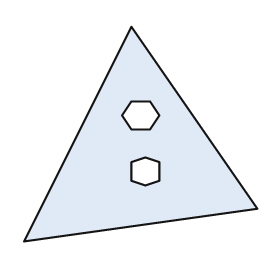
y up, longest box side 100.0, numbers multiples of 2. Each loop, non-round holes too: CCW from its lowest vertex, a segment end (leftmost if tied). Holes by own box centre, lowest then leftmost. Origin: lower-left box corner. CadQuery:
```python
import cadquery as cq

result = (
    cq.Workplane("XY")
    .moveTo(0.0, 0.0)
    .lineTo(100.0, 14.0)
    .lineTo(46.0, 92.0)
    .close()
    .moveTo(52.0, 24.0)
    .lineTo(58.0, 26.0)
    .lineTo(58.0, 34.0)
    .lineTo(52.0, 36.0)
    .lineTo(46.0, 34.0)
    .lineTo(46.0, 26.0)
    .close()
    .moveTo(46.0, 48.0)
    .lineTo(54.0, 48.0)
    .lineTo(58.0, 54.0)
    .lineTo(54.0, 60.0)
    .lineTo(46.0, 60.0)
    .lineTo(42.0, 54.0)
    .close()
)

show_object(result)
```